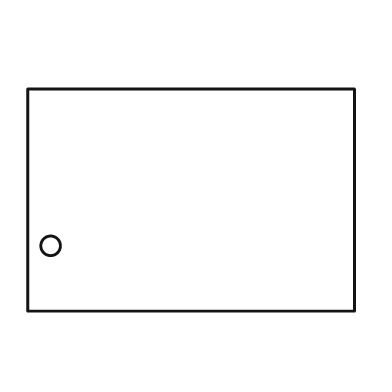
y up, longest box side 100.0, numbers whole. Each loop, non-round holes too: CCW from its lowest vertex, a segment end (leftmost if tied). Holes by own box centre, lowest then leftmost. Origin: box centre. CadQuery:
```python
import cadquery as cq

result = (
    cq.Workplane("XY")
    .moveTo(-50.0, -34.0)
    .lineTo(50.0, -34.0)
    .lineTo(50.0, 34.0)
    .lineTo(-50.0, 34.0)
    .close()
    .moveTo(-43.0, -14.0)
    .circle(3.0)
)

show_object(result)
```